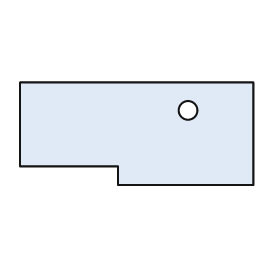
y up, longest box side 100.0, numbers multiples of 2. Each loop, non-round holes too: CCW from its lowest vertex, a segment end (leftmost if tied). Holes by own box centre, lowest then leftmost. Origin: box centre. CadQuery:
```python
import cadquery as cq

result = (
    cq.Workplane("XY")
    .moveTo(-8.0, -22.0)
    .lineTo(50.0, -22.0)
    .lineTo(50.0, 22.0)
    .lineTo(-50.0, 22.0)
    .lineTo(-50.0, -14.0)
    .lineTo(-8.0, -14.0)
    .close()
    .moveTo(22.0, 10.0)
    .circle(4.0)
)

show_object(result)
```